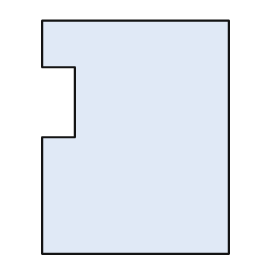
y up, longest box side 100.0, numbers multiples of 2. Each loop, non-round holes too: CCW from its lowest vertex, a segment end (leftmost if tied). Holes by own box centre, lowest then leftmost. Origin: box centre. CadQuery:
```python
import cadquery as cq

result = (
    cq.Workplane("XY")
    .moveTo(-40.0, -50.0)
    .lineTo(40.0, -50.0)
    .lineTo(40.0, 50.0)
    .lineTo(-40.0, 50.0)
    .lineTo(-40.0, 30.0)
    .lineTo(-26.0, 30.0)
    .lineTo(-26.0, 0.0)
    .lineTo(-40.0, 0.0)
    .close()
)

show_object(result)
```